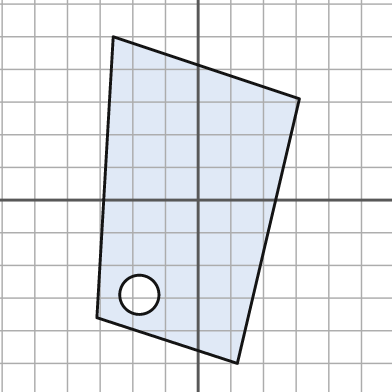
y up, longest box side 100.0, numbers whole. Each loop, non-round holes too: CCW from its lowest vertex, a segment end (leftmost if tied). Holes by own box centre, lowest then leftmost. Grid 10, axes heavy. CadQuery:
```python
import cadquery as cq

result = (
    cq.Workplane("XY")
    .moveTo(12.0, -50.0)
    .lineTo(31.0, 31.0)
    .lineTo(-26.0, 50.0)
    .lineTo(-31.0, -36.0)
    .close()
    .moveTo(-18.0, -29.0)
    .circle(6.0)
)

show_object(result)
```